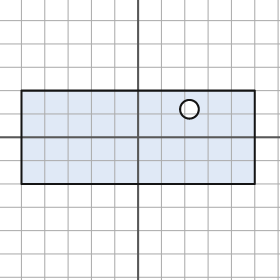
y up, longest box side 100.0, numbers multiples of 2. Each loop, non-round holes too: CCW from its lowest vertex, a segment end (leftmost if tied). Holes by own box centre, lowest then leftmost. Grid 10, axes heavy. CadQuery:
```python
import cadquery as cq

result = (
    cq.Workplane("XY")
    .moveTo(-50.0, -20.0)
    .lineTo(50.0, -20.0)
    .lineTo(50.0, 20.0)
    .lineTo(-50.0, 20.0)
    .close()
    .moveTo(22.0, 12.0)
    .circle(4.0)
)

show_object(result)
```